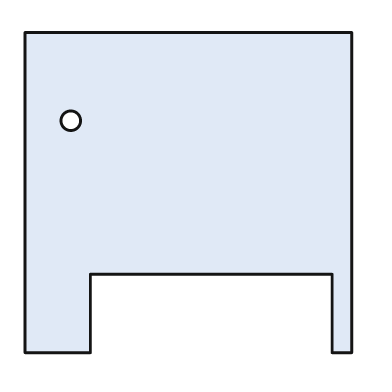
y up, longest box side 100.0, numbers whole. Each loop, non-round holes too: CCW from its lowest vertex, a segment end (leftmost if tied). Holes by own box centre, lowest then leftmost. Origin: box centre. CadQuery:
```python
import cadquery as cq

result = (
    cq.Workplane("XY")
    .moveTo(-50.0, -49.0)
    .lineTo(-30.0, -49.0)
    .lineTo(-30.0, -25.0)
    .lineTo(44.0, -25.0)
    .lineTo(44.0, -49.0)
    .lineTo(50.0, -49.0)
    .lineTo(50.0, 49.0)
    .lineTo(-50.0, 49.0)
    .close()
    .moveTo(-36.0, 22.0)
    .circle(3.0)
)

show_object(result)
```